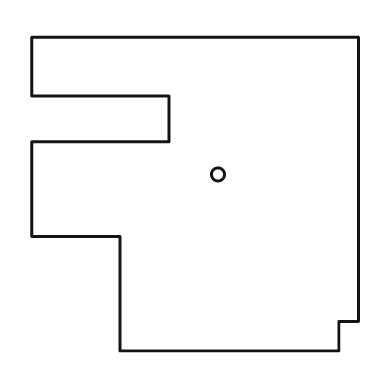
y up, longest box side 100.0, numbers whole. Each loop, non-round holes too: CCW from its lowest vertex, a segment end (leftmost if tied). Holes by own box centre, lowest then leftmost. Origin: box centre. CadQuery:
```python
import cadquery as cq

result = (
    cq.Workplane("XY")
    .moveTo(-23.0, -48.0)
    .lineTo(44.0, -48.0)
    .lineTo(44.0, -39.0)
    .lineTo(50.0, -39.0)
    .lineTo(50.0, 48.0)
    .lineTo(-50.0, 48.0)
    .lineTo(-50.0, 30.0)
    .lineTo(-8.0, 30.0)
    .lineTo(-8.0, 16.0)
    .lineTo(-50.0, 16.0)
    .lineTo(-50.0, -13.0)
    .lineTo(-23.0, -13.0)
    .close()
    .moveTo(7.0, 6.0)
    .circle(2.0)
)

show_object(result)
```